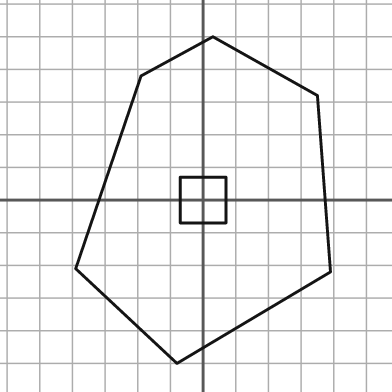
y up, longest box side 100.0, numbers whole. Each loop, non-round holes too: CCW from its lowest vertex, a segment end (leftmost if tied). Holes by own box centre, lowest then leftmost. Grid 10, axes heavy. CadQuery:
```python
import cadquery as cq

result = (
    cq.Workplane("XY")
    .moveTo(-8.0, -50.0)
    .lineTo(39.0, -22.0)
    .lineTo(35.0, 32.0)
    .lineTo(3.0, 50.0)
    .lineTo(-19.0, 38.0)
    .lineTo(-39.0, -21.0)
    .close()
    .moveTo(-7.0, -7.0)
    .lineTo(7.0, -7.0)
    .lineTo(7.0, 7.0)
    .lineTo(-7.0, 7.0)
    .close()
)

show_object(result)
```